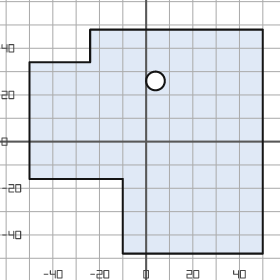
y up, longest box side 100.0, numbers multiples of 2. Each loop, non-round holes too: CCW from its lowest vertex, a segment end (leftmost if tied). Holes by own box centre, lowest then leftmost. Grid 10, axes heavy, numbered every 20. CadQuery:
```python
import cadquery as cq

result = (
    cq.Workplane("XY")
    .moveTo(-10.0, -48.0)
    .lineTo(50.0, -48.0)
    .lineTo(50.0, 48.0)
    .lineTo(-24.0, 48.0)
    .lineTo(-24.0, 34.0)
    .lineTo(-50.0, 34.0)
    .lineTo(-50.0, -16.0)
    .lineTo(-10.0, -16.0)
    .close()
    .moveTo(4.0, 26.0)
    .circle(4.0)
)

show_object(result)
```